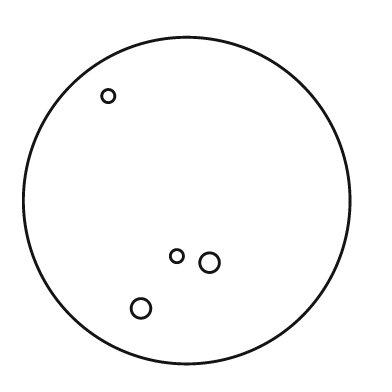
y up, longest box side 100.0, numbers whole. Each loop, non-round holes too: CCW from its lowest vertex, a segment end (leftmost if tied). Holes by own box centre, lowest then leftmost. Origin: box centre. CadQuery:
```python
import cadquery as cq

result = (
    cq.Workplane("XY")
    .moveTo(0.0, 0.0)
    .circle(50.0)
    .moveTo(-14.0, -33.0)
    .circle(3.0)
    .moveTo(7.0, -19.0)
    .circle(3.0)
    .moveTo(-3.0, -17.0)
    .circle(2.0)
    .moveTo(-24.0, 32.0)
    .circle(2.0)
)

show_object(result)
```